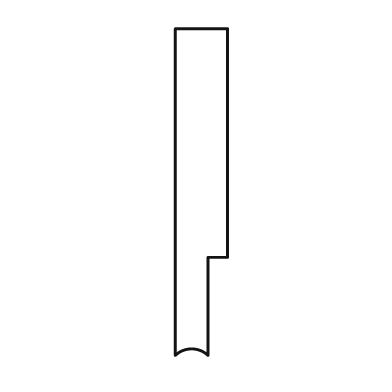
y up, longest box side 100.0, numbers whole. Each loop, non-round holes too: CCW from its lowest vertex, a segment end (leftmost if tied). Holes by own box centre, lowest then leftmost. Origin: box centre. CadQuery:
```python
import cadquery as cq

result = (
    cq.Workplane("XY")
    .moveTo(-8.0, -50.0)
    .threePointArc((-3.0, -48.0), (2.0, -50.0))
    .lineTo(2.0, -20.0)
    .lineTo(8.0, -20.0)
    .lineTo(8.0, 50.0)
    .lineTo(-8.0, 50.0)
    .close()
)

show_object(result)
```